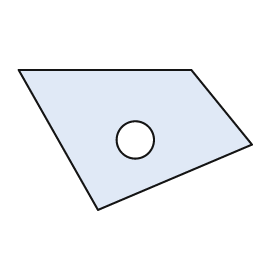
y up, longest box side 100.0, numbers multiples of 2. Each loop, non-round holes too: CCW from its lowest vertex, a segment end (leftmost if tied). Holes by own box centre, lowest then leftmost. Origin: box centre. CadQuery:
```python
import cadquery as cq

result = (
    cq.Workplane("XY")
    .moveTo(-16.0, -30.0)
    .lineTo(50.0, -2.0)
    .lineTo(24.0, 30.0)
    .lineTo(-50.0, 30.0)
    .close()
    .moveTo(0.0, 0.0)
    .circle(8.0)
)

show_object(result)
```